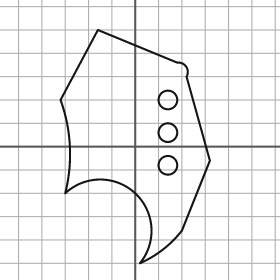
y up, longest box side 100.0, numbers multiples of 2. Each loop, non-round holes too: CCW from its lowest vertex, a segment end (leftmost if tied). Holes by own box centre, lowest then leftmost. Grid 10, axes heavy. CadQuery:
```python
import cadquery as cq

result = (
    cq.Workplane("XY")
    .moveTo(2.0, -50.0)
    .threePointArc((12.0, -44.0), (20.0, -36.0))
    .lineTo(32.0, -6.0)
    .lineTo(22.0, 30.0)
    .threePointArc((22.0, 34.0), (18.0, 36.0))
    .lineTo(-16.0, 50.0)
    .lineTo(-32.0, 20.0)
    .threePointArc((-28.0, 0.0), (-30.0, -20.0))
    .threePointArc((0.0, -20.0), (2.0, -50.0))
    .close()
    .moveTo(14.0, -8.0)
    .circle(4.0)
    .moveTo(14.0, 6.0)
    .circle(4.0)
    .moveTo(14.0, 20.0)
    .circle(4.0)
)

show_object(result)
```